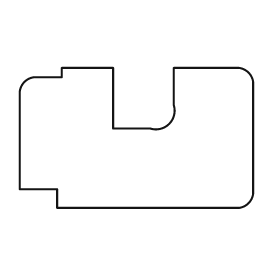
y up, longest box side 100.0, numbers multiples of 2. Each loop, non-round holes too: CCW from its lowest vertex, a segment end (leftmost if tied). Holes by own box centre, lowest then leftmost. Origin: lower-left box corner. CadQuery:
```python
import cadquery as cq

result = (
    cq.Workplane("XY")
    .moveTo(16.0, 0.0)
    .lineTo(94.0, 0.0)
    .threePointArc((98.0, 2.0), (100.0, 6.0))
    .lineTo(100.0, 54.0)
    .threePointArc((98.0, 58.0), (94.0, 60.0))
    .lineTo(66.0, 60.0)
    .lineTo(66.0, 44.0)
    .threePointArc((64.0, 36.0), (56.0, 34.0))
    .lineTo(40.0, 34.0)
    .lineTo(40.0, 60.0)
    .lineTo(18.0, 60.0)
    .lineTo(18.0, 56.0)
    .lineTo(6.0, 56.0)
    .threePointArc((2.0, 54.0), (0.0, 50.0))
    .lineTo(0.0, 8.0)
    .lineTo(16.0, 8.0)
    .close()
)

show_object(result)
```